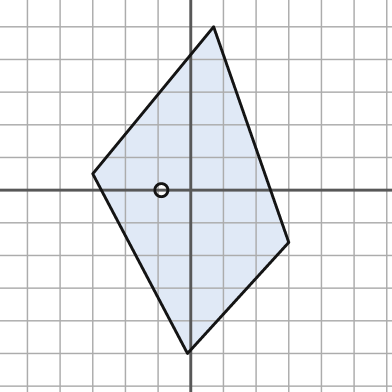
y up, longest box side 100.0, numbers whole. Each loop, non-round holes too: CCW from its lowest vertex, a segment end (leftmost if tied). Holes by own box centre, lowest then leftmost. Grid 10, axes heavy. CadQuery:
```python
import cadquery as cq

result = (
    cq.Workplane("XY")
    .moveTo(-1.0, -50.0)
    .lineTo(30.0, -16.0)
    .lineTo(7.0, 50.0)
    .lineTo(-30.0, 5.0)
    .close()
    .moveTo(-9.0, 0.0)
    .circle(2.0)
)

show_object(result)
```